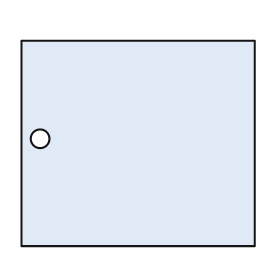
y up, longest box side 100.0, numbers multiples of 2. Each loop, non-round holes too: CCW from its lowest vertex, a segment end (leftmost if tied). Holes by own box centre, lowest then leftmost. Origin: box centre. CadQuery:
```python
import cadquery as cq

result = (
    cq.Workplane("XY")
    .moveTo(-50.0, -44.0)
    .lineTo(50.0, -44.0)
    .lineTo(50.0, 44.0)
    .lineTo(-50.0, 44.0)
    .close()
    .moveTo(-42.0, 2.0)
    .circle(4.0)
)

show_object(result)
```